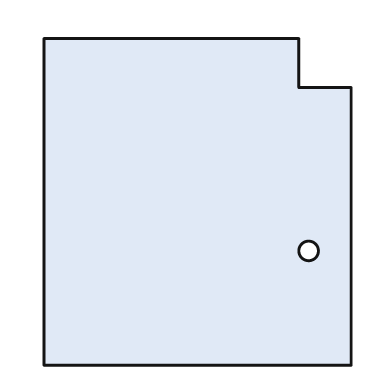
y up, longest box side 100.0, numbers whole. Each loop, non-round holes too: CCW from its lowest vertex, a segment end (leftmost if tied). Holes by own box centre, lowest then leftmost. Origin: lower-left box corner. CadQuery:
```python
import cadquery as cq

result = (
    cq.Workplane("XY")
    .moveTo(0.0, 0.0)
    .lineTo(94.0, 0.0)
    .lineTo(94.0, 85.0)
    .lineTo(78.0, 85.0)
    .lineTo(78.0, 100.0)
    .lineTo(0.0, 100.0)
    .close()
    .moveTo(81.0, 35.0)
    .circle(3.0)
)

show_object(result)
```